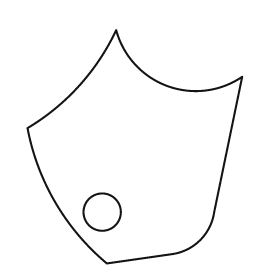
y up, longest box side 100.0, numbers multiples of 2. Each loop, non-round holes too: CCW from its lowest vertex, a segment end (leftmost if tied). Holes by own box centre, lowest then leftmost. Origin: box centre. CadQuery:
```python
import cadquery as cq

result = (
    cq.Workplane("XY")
    .moveTo(-12.0, -50.0)
    .lineTo(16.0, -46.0)
    .threePointArc((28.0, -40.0), (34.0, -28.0))
    .lineTo(46.0, 30.0)
    .threePointArc((14.0, 26.0), (-8.0, 50.0))
    .threePointArc((-24.0, 26.0), (-46.0, 8.0))
    .threePointArc((-34.0, -24.0), (-12.0, -50.0))
    .close()
    .moveTo(-14.0, -28.0)
    .circle(8.0)
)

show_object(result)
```